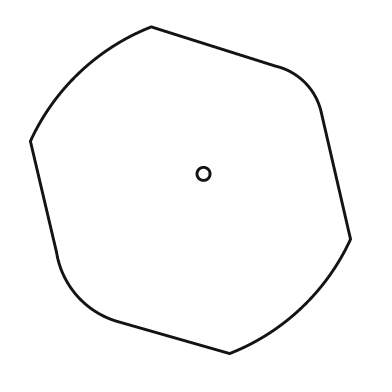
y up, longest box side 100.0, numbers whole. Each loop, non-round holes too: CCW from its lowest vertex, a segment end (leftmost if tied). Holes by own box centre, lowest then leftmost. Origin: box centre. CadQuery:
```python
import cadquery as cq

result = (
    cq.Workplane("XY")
    .moveTo(12.0, -50.0)
    .threePointArc((34.0, -36.0), (49.0, -15.0))
    .lineTo(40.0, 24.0)
    .threePointArc((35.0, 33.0), (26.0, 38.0))
    .lineTo(-12.0, 50.0)
    .threePointArc((-34.0, 36.0), (-49.0, 15.0))
    .lineTo(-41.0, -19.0)
    .threePointArc((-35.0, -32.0), (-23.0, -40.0))
    .close()
    .moveTo(4.0, 5.0)
    .circle(2.0)
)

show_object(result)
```